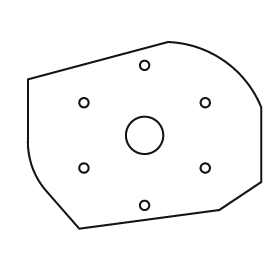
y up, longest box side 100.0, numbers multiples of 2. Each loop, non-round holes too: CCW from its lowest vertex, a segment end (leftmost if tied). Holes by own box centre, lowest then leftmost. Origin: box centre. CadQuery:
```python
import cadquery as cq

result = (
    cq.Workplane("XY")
    .moveTo(-28.0, -40.0)
    .lineTo(32.0, -32.0)
    .lineTo(50.0, -20.0)
    .lineTo(50.0, 12.0)
    .threePointArc((34.0, 32.0), (10.0, 40.0))
    .lineTo(-50.0, 24.0)
    .lineTo(-50.0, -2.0)
    .threePointArc((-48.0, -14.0), (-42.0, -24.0))
    .close()
    .moveTo(0.0, -30.0)
    .circle(2.0)
    .moveTo(-26.0, -14.0)
    .circle(2.0)
    .moveTo(26.0, -14.0)
    .circle(2.0)
    .moveTo(0.0, 0.0)
    .circle(8.0)
    .moveTo(-26.0, 14.0)
    .circle(2.0)
    .moveTo(26.0, 14.0)
    .circle(2.0)
    .moveTo(0.0, 30.0)
    .circle(2.0)
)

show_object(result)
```